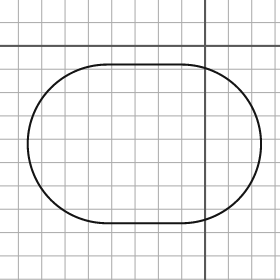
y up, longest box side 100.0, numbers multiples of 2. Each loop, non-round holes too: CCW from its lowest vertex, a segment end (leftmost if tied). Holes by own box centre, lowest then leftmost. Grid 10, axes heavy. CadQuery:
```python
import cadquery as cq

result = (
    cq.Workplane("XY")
    .moveTo(-42.0, -76.0)
    .lineTo(-10.0, -76.0)
    .threePointArc((24.0, -42.0), (-10.0, -8.0))
    .lineTo(-42.0, -8.0)
    .threePointArc((-76.0, -42.0), (-42.0, -76.0))
    .close()
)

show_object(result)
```